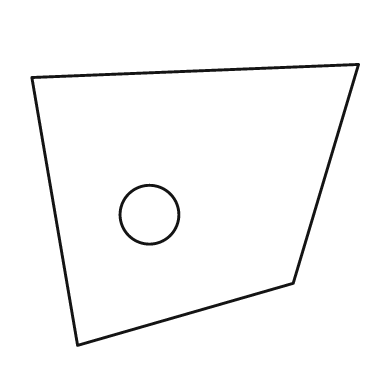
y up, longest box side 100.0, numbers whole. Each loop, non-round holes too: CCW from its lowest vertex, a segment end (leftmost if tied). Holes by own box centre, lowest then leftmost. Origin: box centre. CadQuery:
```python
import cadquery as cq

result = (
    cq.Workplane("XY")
    .moveTo(-36.0, -43.0)
    .lineTo(30.0, -24.0)
    .lineTo(50.0, 43.0)
    .lineTo(-50.0, 39.0)
    .close()
    .moveTo(-14.0, -3.0)
    .circle(9.0)
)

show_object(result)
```